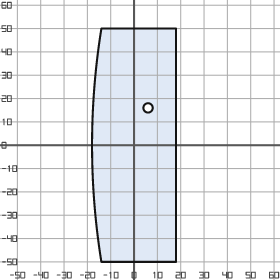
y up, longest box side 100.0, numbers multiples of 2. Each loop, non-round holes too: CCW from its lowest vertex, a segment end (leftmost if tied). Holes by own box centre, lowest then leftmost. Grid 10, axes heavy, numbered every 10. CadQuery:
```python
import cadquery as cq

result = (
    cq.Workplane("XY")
    .moveTo(-14.0, -50.0)
    .lineTo(18.0, -50.0)
    .lineTo(18.0, 50.0)
    .lineTo(-14.0, 50.0)
    .threePointArc((-18.0, 0.0), (-14.0, -50.0))
    .close()
    .moveTo(6.0, 16.0)
    .circle(2.0)
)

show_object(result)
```